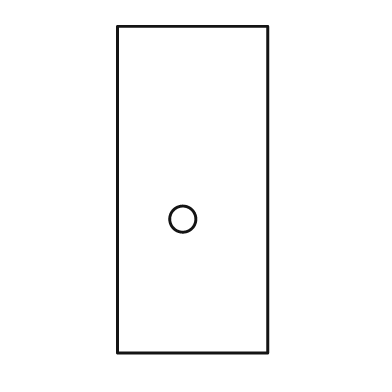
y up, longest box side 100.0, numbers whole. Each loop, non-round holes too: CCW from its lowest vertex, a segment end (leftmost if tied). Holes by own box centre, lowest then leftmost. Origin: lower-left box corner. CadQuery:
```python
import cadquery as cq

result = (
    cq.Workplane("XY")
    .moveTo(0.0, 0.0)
    .lineTo(46.0, 0.0)
    .lineTo(46.0, 100.0)
    .lineTo(0.0, 100.0)
    .close()
    .moveTo(20.0, 41.0)
    .circle(4.0)
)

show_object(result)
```